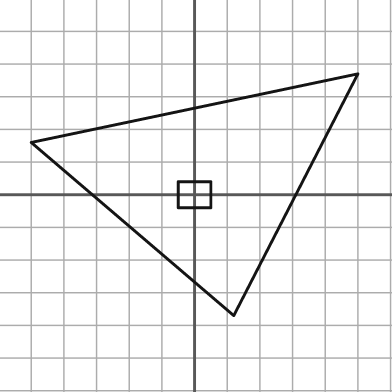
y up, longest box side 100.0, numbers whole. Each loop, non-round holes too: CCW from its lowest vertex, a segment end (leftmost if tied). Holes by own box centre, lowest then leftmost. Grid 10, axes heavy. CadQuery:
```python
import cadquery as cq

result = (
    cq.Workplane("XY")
    .moveTo(12.0, -37.0)
    .lineTo(50.0, 37.0)
    .lineTo(-50.0, 16.0)
    .close()
    .moveTo(-5.0, -4.0)
    .lineTo(5.0, -4.0)
    .lineTo(5.0, 4.0)
    .lineTo(-5.0, 4.0)
    .close()
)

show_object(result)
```